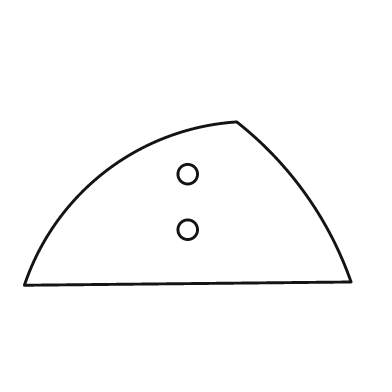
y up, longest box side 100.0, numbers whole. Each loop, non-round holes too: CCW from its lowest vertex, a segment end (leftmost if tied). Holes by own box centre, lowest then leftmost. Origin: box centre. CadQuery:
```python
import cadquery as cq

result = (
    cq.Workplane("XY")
    .moveTo(-50.0, -25.0)
    .lineTo(50.0, -24.0)
    .threePointArc((36.0, 3.0), (15.0, 25.0))
    .threePointArc((-25.0, 10.0), (-50.0, -25.0))
    .close()
    .moveTo(0.0, -8.0)
    .circle(3.0)
    .moveTo(0.0, 9.0)
    .circle(3.0)
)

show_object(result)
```